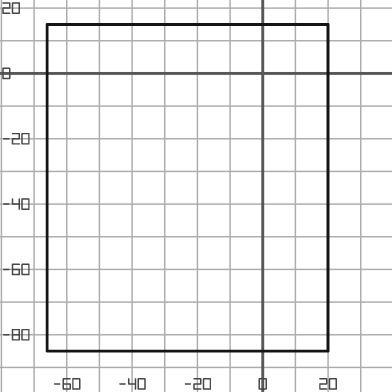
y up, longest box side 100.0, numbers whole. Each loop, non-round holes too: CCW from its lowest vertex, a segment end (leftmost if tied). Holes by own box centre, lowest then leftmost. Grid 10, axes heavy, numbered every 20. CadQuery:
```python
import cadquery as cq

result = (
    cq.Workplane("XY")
    .moveTo(-66.0, -85.0)
    .lineTo(20.0, -85.0)
    .lineTo(20.0, 15.0)
    .lineTo(-66.0, 15.0)
    .close()
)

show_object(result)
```